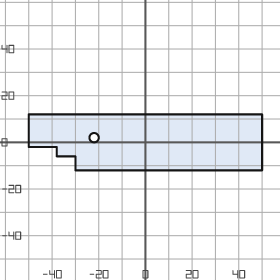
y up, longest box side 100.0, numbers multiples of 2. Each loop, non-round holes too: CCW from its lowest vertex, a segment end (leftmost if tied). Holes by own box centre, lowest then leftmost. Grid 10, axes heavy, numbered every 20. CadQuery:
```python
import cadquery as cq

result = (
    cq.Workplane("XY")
    .moveTo(-30.0, -12.0)
    .lineTo(50.0, -12.0)
    .lineTo(50.0, 12.0)
    .lineTo(-50.0, 12.0)
    .lineTo(-50.0, -2.0)
    .lineTo(-38.0, -2.0)
    .lineTo(-38.0, -6.0)
    .lineTo(-30.0, -6.0)
    .close()
    .moveTo(-22.0, 2.0)
    .circle(2.0)
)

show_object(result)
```